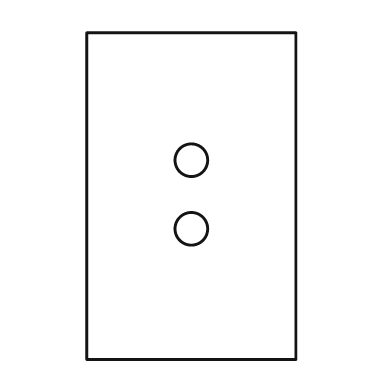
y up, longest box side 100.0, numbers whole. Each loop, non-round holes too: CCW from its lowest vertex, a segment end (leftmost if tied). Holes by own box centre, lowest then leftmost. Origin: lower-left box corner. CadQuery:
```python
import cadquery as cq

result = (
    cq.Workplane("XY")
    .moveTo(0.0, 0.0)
    .lineTo(64.0, 0.0)
    .lineTo(64.0, 100.0)
    .lineTo(0.0, 100.0)
    .close()
    .moveTo(32.0, 40.0)
    .circle(5.0)
    .moveTo(32.0, 61.0)
    .circle(5.0)
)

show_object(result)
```